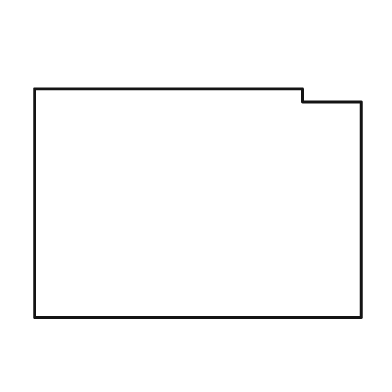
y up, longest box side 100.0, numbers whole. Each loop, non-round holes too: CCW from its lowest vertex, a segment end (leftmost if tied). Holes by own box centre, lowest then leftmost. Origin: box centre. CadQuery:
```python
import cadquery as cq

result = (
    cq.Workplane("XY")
    .moveTo(-50.0, -35.0)
    .lineTo(50.0, -35.0)
    .lineTo(50.0, 31.0)
    .lineTo(32.0, 31.0)
    .lineTo(32.0, 35.0)
    .lineTo(-50.0, 35.0)
    .close()
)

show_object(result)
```